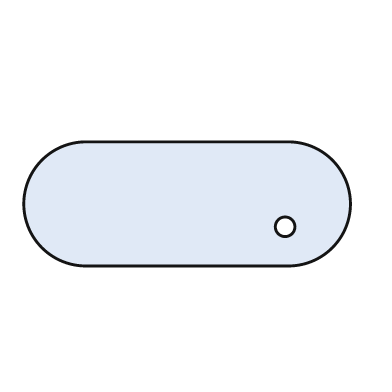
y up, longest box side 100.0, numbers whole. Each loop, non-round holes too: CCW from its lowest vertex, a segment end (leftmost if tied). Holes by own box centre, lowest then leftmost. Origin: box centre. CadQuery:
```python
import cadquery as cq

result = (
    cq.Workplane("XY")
    .moveTo(-31.0, -19.0)
    .lineTo(31.0, -19.0)
    .threePointArc((50.0, 0.0), (31.0, 19.0))
    .lineTo(-31.0, 19.0)
    .threePointArc((-50.0, 0.0), (-31.0, -19.0))
    .close()
    .moveTo(30.0, -7.0)
    .circle(3.0)
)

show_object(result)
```